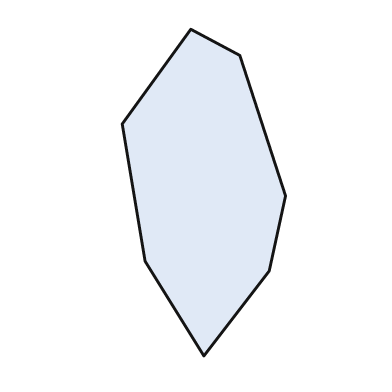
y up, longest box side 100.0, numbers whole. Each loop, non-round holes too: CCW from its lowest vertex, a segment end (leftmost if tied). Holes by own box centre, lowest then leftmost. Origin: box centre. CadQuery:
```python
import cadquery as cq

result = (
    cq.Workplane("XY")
    .moveTo(0.0, -50.0)
    .lineTo(20.0, -24.0)
    .lineTo(25.0, -1.0)
    .lineTo(11.0, 42.0)
    .lineTo(-4.0, 50.0)
    .lineTo(-25.0, 21.0)
    .lineTo(-18.0, -21.0)
    .close()
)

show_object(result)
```